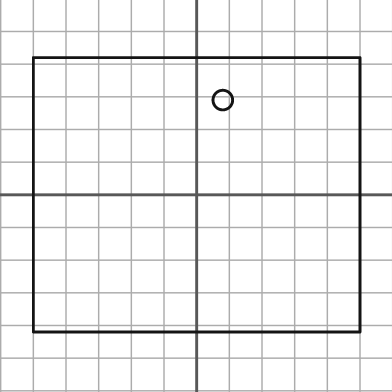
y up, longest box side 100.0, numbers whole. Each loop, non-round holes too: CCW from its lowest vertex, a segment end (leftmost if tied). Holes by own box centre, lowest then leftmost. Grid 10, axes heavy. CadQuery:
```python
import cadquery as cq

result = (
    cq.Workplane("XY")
    .moveTo(-50.0, -42.0)
    .lineTo(50.0, -42.0)
    .lineTo(50.0, 42.0)
    .lineTo(-50.0, 42.0)
    .close()
    .moveTo(8.0, 29.0)
    .circle(3.0)
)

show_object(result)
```